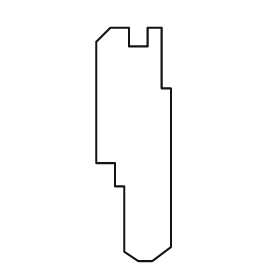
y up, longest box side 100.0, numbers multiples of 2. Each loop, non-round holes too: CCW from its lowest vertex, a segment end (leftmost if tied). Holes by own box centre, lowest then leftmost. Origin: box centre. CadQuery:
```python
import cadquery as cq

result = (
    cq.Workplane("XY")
    .moveTo(2.0, -50.0)
    .lineTo(8.0, -50.0)
    .lineTo(16.0, -44.0)
    .lineTo(16.0, 24.0)
    .lineTo(12.0, 24.0)
    .lineTo(12.0, 50.0)
    .lineTo(6.0, 50.0)
    .lineTo(6.0, 42.0)
    .lineTo(-2.0, 42.0)
    .lineTo(-2.0, 50.0)
    .lineTo(-10.0, 50.0)
    .lineTo(-16.0, 44.0)
    .lineTo(-16.0, -8.0)
    .lineTo(-8.0, -8.0)
    .lineTo(-8.0, -18.0)
    .lineTo(-4.0, -18.0)
    .lineTo(-4.0, -46.0)
    .close()
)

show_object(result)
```